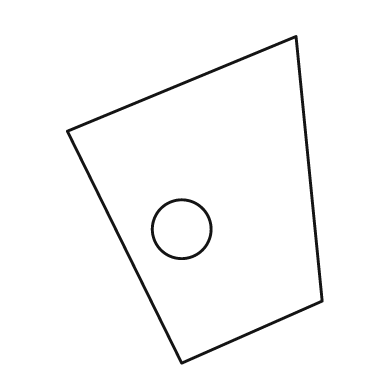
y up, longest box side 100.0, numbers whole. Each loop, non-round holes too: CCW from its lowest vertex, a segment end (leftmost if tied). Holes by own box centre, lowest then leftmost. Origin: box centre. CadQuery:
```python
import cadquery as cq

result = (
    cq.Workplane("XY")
    .moveTo(-4.0, -50.0)
    .lineTo(39.0, -31.0)
    .lineTo(31.0, 50.0)
    .lineTo(-39.0, 21.0)
    .close()
    .moveTo(-4.0, -9.0)
    .circle(9.0)
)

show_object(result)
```